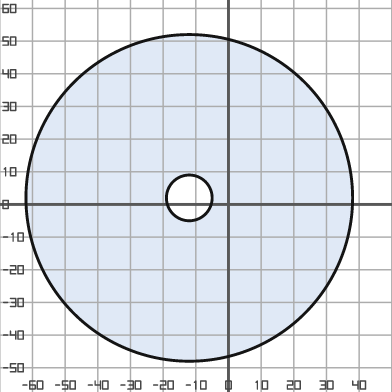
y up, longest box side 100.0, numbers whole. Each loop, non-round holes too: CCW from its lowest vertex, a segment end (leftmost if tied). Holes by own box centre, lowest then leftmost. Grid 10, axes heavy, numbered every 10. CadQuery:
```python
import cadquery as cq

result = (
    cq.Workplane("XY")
    .moveTo(-12.0, 2.0)
    .circle(50.0)
    .moveTo(-12.0, 2.0)
    .circle(7.0)
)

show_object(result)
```